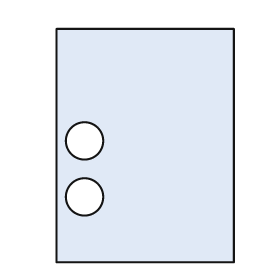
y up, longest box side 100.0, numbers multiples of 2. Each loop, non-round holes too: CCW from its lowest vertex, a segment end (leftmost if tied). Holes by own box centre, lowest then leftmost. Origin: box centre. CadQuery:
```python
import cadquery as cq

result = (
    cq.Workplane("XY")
    .moveTo(-38.0, -50.0)
    .lineTo(38.0, -50.0)
    .lineTo(38.0, 50.0)
    .lineTo(-38.0, 50.0)
    .close()
    .moveTo(-26.0, -22.0)
    .circle(8.0)
    .moveTo(-26.0, 2.0)
    .circle(8.0)
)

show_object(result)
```